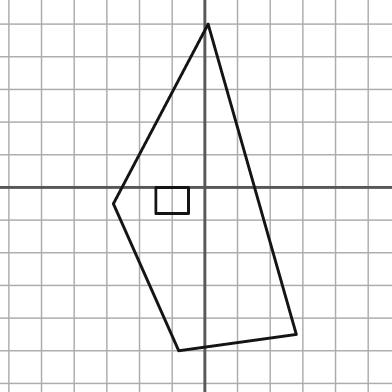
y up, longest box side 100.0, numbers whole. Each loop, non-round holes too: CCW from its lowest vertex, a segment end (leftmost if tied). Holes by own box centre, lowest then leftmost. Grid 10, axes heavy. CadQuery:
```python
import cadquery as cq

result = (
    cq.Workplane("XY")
    .moveTo(-8.0, -50.0)
    .lineTo(28.0, -45.0)
    .lineTo(1.0, 50.0)
    .lineTo(-28.0, -5.0)
    .close()
    .moveTo(-15.0, -8.0)
    .lineTo(-5.0, -8.0)
    .lineTo(-5.0, 0.0)
    .lineTo(-15.0, 0.0)
    .close()
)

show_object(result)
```